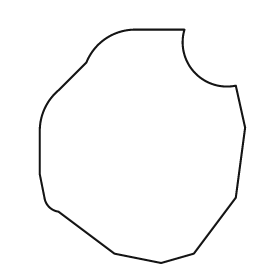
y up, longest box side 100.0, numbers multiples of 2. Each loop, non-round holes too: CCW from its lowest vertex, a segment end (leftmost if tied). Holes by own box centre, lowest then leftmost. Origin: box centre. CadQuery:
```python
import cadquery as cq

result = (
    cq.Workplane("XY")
    .moveTo(8.0, -50.0)
    .lineTo(22.0, -46.0)
    .lineTo(40.0, -22.0)
    .lineTo(44.0, 8.0)
    .lineTo(40.0, 26.0)
    .threePointArc((22.0, 32.0), (18.0, 50.0))
    .lineTo(-4.0, 50.0)
    .threePointArc((-16.0, 46.0), (-24.0, 36.0))
    .lineTo(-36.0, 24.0)
    .threePointArc((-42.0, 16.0), (-44.0, 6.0))
    .lineTo(-44.0, -12.0)
    .lineTo(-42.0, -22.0)
    .threePointArc((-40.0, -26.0), (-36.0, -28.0))
    .lineTo(-12.0, -46.0)
    .close()
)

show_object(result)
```